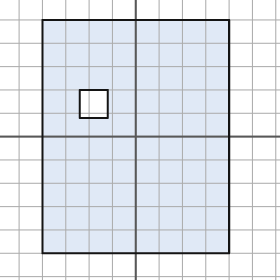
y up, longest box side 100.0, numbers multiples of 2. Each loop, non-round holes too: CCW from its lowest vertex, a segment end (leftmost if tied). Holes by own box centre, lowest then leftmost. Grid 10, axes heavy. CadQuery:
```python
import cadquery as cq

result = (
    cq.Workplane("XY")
    .moveTo(-40.0, -50.0)
    .lineTo(40.0, -50.0)
    .lineTo(40.0, 50.0)
    .lineTo(-40.0, 50.0)
    .close()
    .moveTo(-24.0, 8.0)
    .lineTo(-12.0, 8.0)
    .lineTo(-12.0, 20.0)
    .lineTo(-24.0, 20.0)
    .close()
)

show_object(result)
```